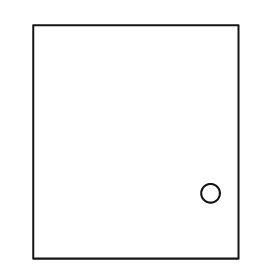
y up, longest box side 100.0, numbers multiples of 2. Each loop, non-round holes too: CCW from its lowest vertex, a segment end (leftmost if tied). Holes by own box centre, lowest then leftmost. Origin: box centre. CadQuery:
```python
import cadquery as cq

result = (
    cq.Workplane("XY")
    .moveTo(-44.0, -50.0)
    .lineTo(44.0, -50.0)
    .lineTo(44.0, 50.0)
    .lineTo(-44.0, 50.0)
    .close()
    .moveTo(32.0, -22.0)
    .circle(4.0)
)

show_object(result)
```